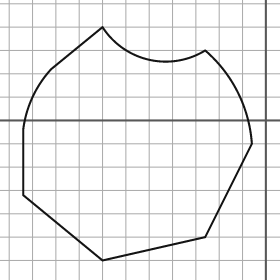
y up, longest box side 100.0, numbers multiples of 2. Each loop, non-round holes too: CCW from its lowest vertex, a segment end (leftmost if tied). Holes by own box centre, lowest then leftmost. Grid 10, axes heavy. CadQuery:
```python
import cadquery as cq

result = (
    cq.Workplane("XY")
    .moveTo(-70.0, -60.0)
    .lineTo(-26.0, -50.0)
    .lineTo(-6.0, -10.0)
    .threePointArc((-12.0, 12.0), (-26.0, 30.0))
    .threePointArc((-50.0, 26.0), (-70.0, 40.0))
    .lineTo(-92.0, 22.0)
    .threePointArc((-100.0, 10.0), (-104.0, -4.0))
    .lineTo(-104.0, -32.0)
    .close()
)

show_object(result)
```